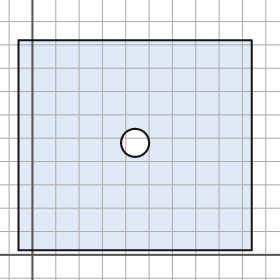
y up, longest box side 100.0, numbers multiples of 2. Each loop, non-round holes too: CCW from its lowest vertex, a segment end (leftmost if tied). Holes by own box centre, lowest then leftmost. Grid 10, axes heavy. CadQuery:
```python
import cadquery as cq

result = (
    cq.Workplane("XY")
    .moveTo(-6.0, 2.0)
    .lineTo(94.0, 2.0)
    .lineTo(94.0, 92.0)
    .lineTo(-6.0, 92.0)
    .close()
    .moveTo(44.0, 48.0)
    .circle(6.0)
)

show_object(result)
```